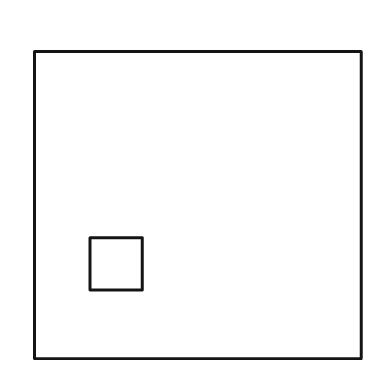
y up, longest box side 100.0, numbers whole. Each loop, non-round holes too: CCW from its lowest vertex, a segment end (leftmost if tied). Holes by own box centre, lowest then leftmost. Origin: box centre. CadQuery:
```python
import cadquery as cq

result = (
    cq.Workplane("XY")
    .moveTo(-50.0, -47.0)
    .lineTo(50.0, -47.0)
    .lineTo(50.0, 47.0)
    .lineTo(-50.0, 47.0)
    .close()
    .moveTo(-33.0, -26.0)
    .lineTo(-17.0, -26.0)
    .lineTo(-17.0, -10.0)
    .lineTo(-33.0, -10.0)
    .close()
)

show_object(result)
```